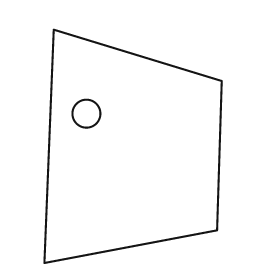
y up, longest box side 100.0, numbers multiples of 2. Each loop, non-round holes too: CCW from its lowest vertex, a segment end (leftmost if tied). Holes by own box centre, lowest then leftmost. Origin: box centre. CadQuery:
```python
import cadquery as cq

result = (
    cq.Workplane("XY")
    .moveTo(-38.0, -50.0)
    .lineTo(36.0, -36.0)
    .lineTo(38.0, 28.0)
    .lineTo(-34.0, 50.0)
    .close()
    .moveTo(-20.0, 14.0)
    .circle(6.0)
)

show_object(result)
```